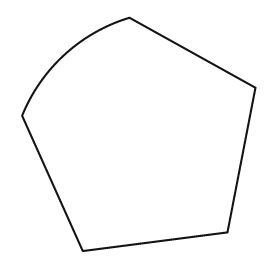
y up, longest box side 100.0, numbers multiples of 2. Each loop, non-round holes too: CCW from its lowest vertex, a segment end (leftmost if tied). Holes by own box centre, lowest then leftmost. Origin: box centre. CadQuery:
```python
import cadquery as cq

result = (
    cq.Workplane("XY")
    .moveTo(-24.0, -50.0)
    .lineTo(38.0, -42.0)
    .lineTo(50.0, 20.0)
    .lineTo(-4.0, 50.0)
    .threePointArc((-32.0, 34.0), (-50.0, 8.0))
    .close()
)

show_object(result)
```